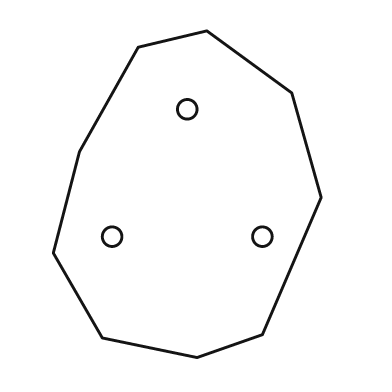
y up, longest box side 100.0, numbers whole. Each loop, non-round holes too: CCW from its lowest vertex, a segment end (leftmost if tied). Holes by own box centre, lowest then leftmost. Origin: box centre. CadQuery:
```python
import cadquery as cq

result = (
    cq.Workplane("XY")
    .moveTo(3.0, -50.0)
    .lineTo(23.0, -43.0)
    .lineTo(41.0, -1.0)
    .lineTo(32.0, 31.0)
    .lineTo(6.0, 50.0)
    .lineTo(-15.0, 45.0)
    .lineTo(-33.0, 13.0)
    .lineTo(-41.0, -18.0)
    .lineTo(-26.0, -44.0)
    .close()
    .moveTo(-23.0, -13.0)
    .circle(3.0)
    .moveTo(23.0, -13.0)
    .circle(3.0)
    .moveTo(0.0, 26.0)
    .circle(3.0)
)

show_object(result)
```